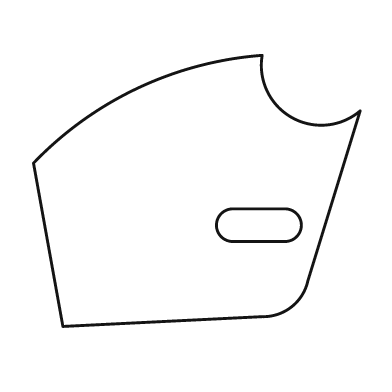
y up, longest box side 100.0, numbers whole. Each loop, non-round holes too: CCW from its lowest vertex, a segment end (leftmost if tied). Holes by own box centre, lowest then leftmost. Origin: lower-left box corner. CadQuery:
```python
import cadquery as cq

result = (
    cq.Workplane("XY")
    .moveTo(9.0, 0.0)
    .lineTo(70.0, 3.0)
    .threePointArc((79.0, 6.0), (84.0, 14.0))
    .lineTo(100.0, 66.0)
    .threePointArc((79.0, 64.0), (70.0, 83.0))
    .threePointArc((32.0, 73.0), (0.0, 50.0))
    .close()
    .moveTo(61.0, 26.0)
    .lineTo(77.0, 26.0)
    .threePointArc((82.0, 31.0), (77.0, 36.0))
    .lineTo(61.0, 36.0)
    .threePointArc((56.0, 31.0), (61.0, 26.0))
    .close()
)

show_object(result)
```